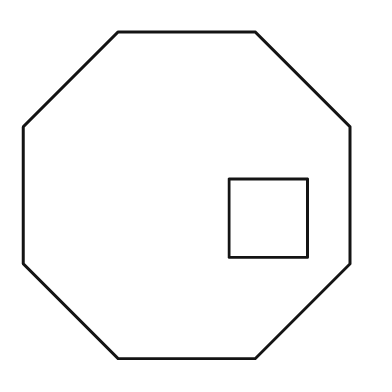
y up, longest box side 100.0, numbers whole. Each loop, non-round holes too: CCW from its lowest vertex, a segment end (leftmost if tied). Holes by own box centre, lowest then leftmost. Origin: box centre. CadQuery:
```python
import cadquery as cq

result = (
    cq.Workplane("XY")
    .moveTo(-21.0, -50.0)
    .lineTo(21.0, -50.0)
    .lineTo(50.0, -21.0)
    .lineTo(50.0, 21.0)
    .lineTo(21.0, 50.0)
    .lineTo(-21.0, 50.0)
    .lineTo(-50.0, 21.0)
    .lineTo(-50.0, -21.0)
    .close()
    .moveTo(13.0, -19.0)
    .lineTo(37.0, -19.0)
    .lineTo(37.0, 5.0)
    .lineTo(13.0, 5.0)
    .close()
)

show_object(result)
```